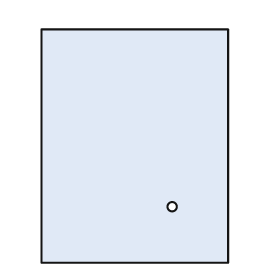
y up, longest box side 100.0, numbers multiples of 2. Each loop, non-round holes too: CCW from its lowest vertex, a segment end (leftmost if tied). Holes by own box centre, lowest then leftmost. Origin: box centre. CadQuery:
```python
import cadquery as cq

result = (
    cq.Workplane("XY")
    .moveTo(-40.0, -50.0)
    .lineTo(40.0, -50.0)
    .lineTo(40.0, 50.0)
    .lineTo(-40.0, 50.0)
    .close()
    .moveTo(16.0, -26.0)
    .circle(2.0)
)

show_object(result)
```